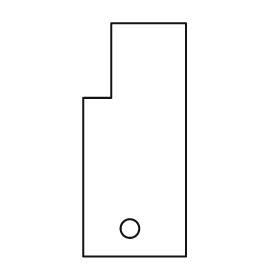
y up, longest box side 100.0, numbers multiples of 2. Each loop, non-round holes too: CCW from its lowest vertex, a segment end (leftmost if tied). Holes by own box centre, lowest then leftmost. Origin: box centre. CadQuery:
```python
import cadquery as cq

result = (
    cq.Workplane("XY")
    .moveTo(-22.0, -50.0)
    .lineTo(22.0, -50.0)
    .lineTo(22.0, 50.0)
    .lineTo(-10.0, 50.0)
    .lineTo(-10.0, 18.0)
    .lineTo(-22.0, 18.0)
    .close()
    .moveTo(-2.0, -38.0)
    .circle(4.0)
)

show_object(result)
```